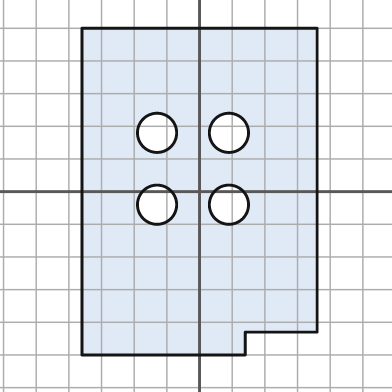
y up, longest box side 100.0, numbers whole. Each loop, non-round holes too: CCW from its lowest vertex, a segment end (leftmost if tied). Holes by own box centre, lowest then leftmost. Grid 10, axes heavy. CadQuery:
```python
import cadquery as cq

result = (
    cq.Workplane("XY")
    .moveTo(-36.0, -50.0)
    .lineTo(14.0, -50.0)
    .lineTo(14.0, -43.0)
    .lineTo(36.0, -43.0)
    .lineTo(36.0, 50.0)
    .lineTo(-36.0, 50.0)
    .close()
    .moveTo(-13.0, -4.0)
    .circle(6.0)
    .moveTo(9.0, -4.0)
    .circle(6.0)
    .moveTo(-13.0, 18.0)
    .circle(6.0)
    .moveTo(9.0, 18.0)
    .circle(6.0)
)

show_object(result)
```